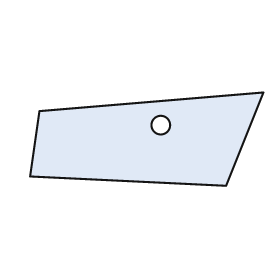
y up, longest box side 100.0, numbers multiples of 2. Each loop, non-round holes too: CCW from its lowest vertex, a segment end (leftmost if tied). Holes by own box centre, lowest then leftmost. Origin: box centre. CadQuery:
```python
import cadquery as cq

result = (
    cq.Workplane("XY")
    .moveTo(34.0, -20.0)
    .lineTo(50.0, 20.0)
    .lineTo(-46.0, 12.0)
    .lineTo(-50.0, -16.0)
    .close()
    .moveTo(6.0, 6.0)
    .circle(4.0)
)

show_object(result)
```